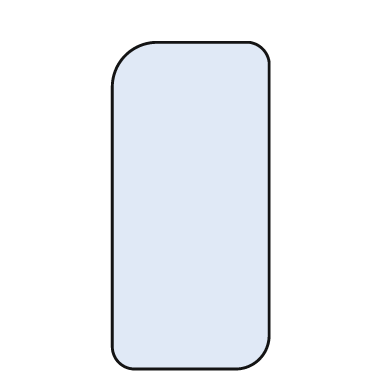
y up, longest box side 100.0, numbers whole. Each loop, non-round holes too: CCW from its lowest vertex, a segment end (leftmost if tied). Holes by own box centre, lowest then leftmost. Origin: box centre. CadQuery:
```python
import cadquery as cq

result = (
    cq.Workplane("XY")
    .moveTo(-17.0, -50.0)
    .lineTo(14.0, -50.0)
    .threePointArc((21.0, -47.0), (24.0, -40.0))
    .lineTo(24.0, 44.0)
    .threePointArc((22.0, 48.0), (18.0, 50.0))
    .lineTo(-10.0, 50.0)
    .threePointArc((-20.0, 46.0), (-24.0, 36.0))
    .lineTo(-24.0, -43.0)
    .threePointArc((-22.0, -48.0), (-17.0, -50.0))
    .close()
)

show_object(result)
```